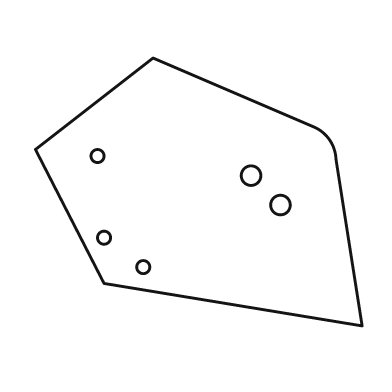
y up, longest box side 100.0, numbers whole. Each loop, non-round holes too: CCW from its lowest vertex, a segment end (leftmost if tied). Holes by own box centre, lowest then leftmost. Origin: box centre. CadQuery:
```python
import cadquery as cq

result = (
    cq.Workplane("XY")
    .moveTo(50.0, -41.0)
    .lineTo(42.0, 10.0)
    .threePointArc((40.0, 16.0), (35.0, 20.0))
    .lineTo(-14.0, 41.0)
    .lineTo(-50.0, 13.0)
    .lineTo(-29.0, -28.0)
    .close()
    .moveTo(-17.0, -23.0)
    .circle(2.0)
    .moveTo(-29.0, -14.0)
    .circle(2.0)
    .moveTo(25.0, -4.0)
    .circle(3.0)
    .moveTo(16.0, 5.0)
    .circle(3.0)
    .moveTo(-31.0, 11.0)
    .circle(2.0)
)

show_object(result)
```